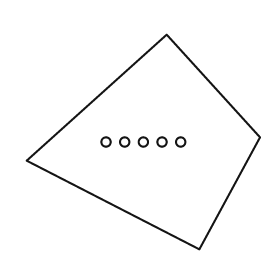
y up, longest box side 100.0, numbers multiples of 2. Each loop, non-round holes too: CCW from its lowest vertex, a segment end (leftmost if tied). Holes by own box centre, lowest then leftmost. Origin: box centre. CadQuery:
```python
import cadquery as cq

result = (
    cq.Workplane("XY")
    .moveTo(24.0, -46.0)
    .lineTo(50.0, 2.0)
    .lineTo(10.0, 46.0)
    .lineTo(-50.0, -8.0)
    .close()
    .moveTo(-16.0, 0.0)
    .circle(2.0)
    .moveTo(-8.0, 0.0)
    .circle(2.0)
    .moveTo(0.0, 0.0)
    .circle(2.0)
    .moveTo(8.0, 0.0)
    .circle(2.0)
    .moveTo(16.0, 0.0)
    .circle(2.0)
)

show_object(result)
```